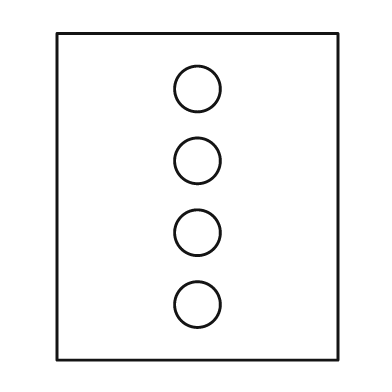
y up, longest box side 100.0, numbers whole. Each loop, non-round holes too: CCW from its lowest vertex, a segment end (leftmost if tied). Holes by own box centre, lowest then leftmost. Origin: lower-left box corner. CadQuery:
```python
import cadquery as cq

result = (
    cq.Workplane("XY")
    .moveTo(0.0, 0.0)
    .lineTo(86.0, 0.0)
    .lineTo(86.0, 100.0)
    .lineTo(0.0, 100.0)
    .close()
    .moveTo(43.0, 17.0)
    .circle(7.0)
    .moveTo(43.0, 39.0)
    .circle(7.0)
    .moveTo(43.0, 61.0)
    .circle(7.0)
    .moveTo(43.0, 83.0)
    .circle(7.0)
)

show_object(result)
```